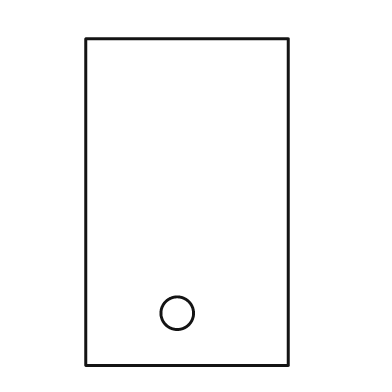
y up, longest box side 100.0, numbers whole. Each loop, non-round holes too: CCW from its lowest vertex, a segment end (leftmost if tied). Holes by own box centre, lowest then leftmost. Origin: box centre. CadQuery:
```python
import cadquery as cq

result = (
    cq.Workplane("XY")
    .moveTo(-31.0, -50.0)
    .lineTo(31.0, -50.0)
    .lineTo(31.0, 50.0)
    .lineTo(-31.0, 50.0)
    .close()
    .moveTo(-3.0, -34.0)
    .circle(5.0)
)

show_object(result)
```